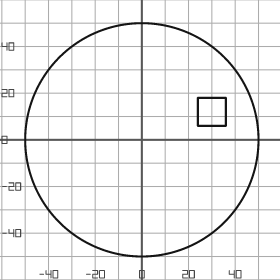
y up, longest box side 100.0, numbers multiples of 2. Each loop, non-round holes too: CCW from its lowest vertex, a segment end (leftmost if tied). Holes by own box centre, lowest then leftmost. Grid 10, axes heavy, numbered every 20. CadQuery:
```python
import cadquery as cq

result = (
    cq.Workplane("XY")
    .moveTo(0.0, 0.0)
    .circle(50.0)
    .moveTo(24.0, 6.0)
    .lineTo(36.0, 6.0)
    .lineTo(36.0, 18.0)
    .lineTo(24.0, 18.0)
    .close()
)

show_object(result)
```